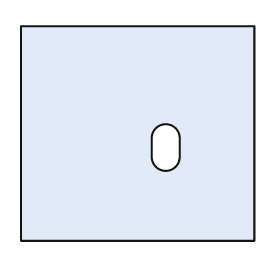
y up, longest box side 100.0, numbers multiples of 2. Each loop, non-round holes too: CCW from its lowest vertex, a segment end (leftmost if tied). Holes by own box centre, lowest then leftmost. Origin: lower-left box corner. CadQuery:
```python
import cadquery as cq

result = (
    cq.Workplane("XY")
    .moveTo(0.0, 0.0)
    .lineTo(100.0, 0.0)
    .lineTo(100.0, 92.0)
    .lineTo(0.0, 92.0)
    .close()
    .moveTo(56.0, 36.0)
    .threePointArc((62.0, 30.0), (68.0, 36.0))
    .lineTo(68.0, 44.0)
    .threePointArc((62.0, 50.0), (56.0, 44.0))
    .close()
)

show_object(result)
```